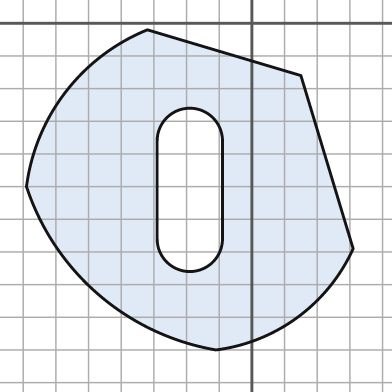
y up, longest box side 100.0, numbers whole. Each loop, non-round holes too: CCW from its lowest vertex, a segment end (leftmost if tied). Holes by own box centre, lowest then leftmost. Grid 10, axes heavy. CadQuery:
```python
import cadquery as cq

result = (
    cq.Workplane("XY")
    .moveTo(-11.0, -100.0)
    .threePointArc((14.0, -90.0), (31.0, -69.0))
    .lineTo(15.0, -16.0)
    .lineTo(-32.0, -2.0)
    .threePointArc((-57.0, -21.0), (-69.0, -50.0))
    .threePointArc((-47.0, -83.0), (-11.0, -100.0))
    .close()
    .moveTo(-29.0, -66.0)
    .threePointArc((-19.0, -76.0), (-9.0, -66.0))
    .lineTo(-9.0, -36.0)
    .threePointArc((-19.0, -26.0), (-29.0, -36.0))
    .close()
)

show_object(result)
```